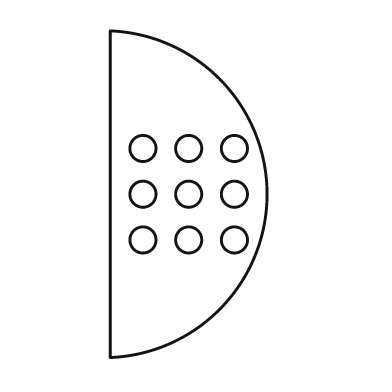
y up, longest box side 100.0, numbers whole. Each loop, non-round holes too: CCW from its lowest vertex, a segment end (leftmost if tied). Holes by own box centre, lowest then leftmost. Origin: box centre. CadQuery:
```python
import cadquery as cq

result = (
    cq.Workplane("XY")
    .moveTo(-24.0, -50.0)
    .threePointArc((24.0, 0.0), (-24.0, 50.0))
    .close()
    .moveTo(-14.0, -14.0)
    .circle(4.0)
    .moveTo(0.0, -14.0)
    .circle(4.0)
    .moveTo(14.0, -14.0)
    .circle(4.0)
    .moveTo(-14.0, 0.0)
    .circle(4.0)
    .moveTo(0.0, 0.0)
    .circle(4.0)
    .moveTo(14.0, 0.0)
    .circle(4.0)
    .moveTo(-14.0, 14.0)
    .circle(4.0)
    .moveTo(0.0, 14.0)
    .circle(4.0)
    .moveTo(14.0, 14.0)
    .circle(4.0)
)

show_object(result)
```